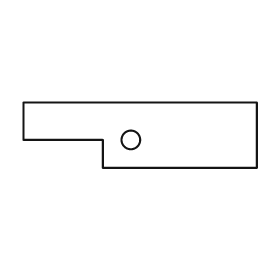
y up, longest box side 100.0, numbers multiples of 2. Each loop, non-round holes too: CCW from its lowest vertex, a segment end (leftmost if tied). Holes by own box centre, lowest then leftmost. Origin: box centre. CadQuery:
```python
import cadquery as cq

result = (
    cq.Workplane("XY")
    .moveTo(-16.0, -14.0)
    .lineTo(50.0, -14.0)
    .lineTo(50.0, 14.0)
    .lineTo(-50.0, 14.0)
    .lineTo(-50.0, -2.0)
    .lineTo(-16.0, -2.0)
    .close()
    .moveTo(-4.0, -2.0)
    .circle(4.0)
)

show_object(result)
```